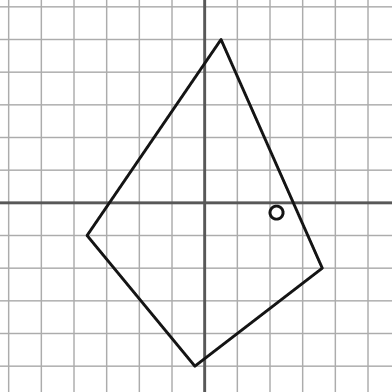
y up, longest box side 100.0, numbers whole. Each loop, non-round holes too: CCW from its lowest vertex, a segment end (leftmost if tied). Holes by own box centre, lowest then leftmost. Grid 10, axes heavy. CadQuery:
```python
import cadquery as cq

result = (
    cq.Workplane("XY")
    .moveTo(-3.0, -50.0)
    .lineTo(36.0, -20.0)
    .lineTo(5.0, 50.0)
    .lineTo(-36.0, -10.0)
    .close()
    .moveTo(22.0, -3.0)
    .circle(2.0)
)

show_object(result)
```